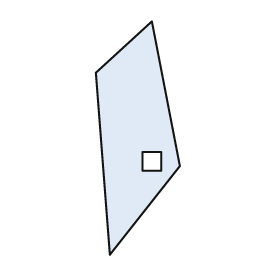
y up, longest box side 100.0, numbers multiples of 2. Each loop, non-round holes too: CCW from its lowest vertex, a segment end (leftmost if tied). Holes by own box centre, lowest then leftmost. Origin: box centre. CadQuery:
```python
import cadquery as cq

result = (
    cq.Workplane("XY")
    .moveTo(-12.0, -50.0)
    .lineTo(18.0, -12.0)
    .lineTo(6.0, 50.0)
    .lineTo(-18.0, 28.0)
    .close()
    .moveTo(2.0, -14.0)
    .lineTo(10.0, -14.0)
    .lineTo(10.0, -6.0)
    .lineTo(2.0, -6.0)
    .close()
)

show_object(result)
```